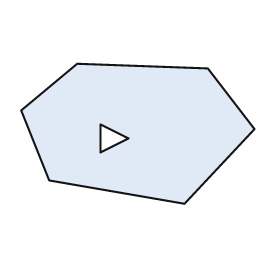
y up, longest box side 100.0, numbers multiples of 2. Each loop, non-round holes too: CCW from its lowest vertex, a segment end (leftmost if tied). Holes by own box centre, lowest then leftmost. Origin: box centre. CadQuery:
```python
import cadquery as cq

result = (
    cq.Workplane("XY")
    .moveTo(20.0, -30.0)
    .lineTo(50.0, 2.0)
    .lineTo(30.0, 28.0)
    .lineTo(-26.0, 30.0)
    .lineTo(-50.0, 10.0)
    .lineTo(-38.0, -20.0)
    .close()
    .moveTo(-16.0, -8.0)
    .lineTo(-4.0, -2.0)
    .lineTo(-16.0, 4.0)
    .close()
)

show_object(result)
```